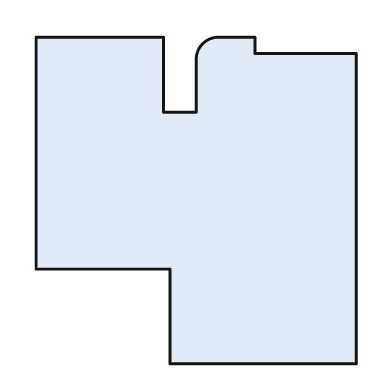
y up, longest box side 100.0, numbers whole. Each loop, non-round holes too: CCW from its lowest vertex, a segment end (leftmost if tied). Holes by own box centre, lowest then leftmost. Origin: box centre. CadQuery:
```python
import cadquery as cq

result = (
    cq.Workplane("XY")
    .moveTo(-8.0, -50.0)
    .lineTo(49.0, -50.0)
    .lineTo(49.0, 45.0)
    .lineTo(18.0, 45.0)
    .lineTo(18.0, 50.0)
    .lineTo(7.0, 50.0)
    .threePointArc((2.0, 48.0), (0.0, 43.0))
    .lineTo(0.0, 27.0)
    .lineTo(-10.0, 27.0)
    .lineTo(-10.0, 50.0)
    .lineTo(-49.0, 50.0)
    .lineTo(-49.0, -21.0)
    .lineTo(-8.0, -21.0)
    .close()
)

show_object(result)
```